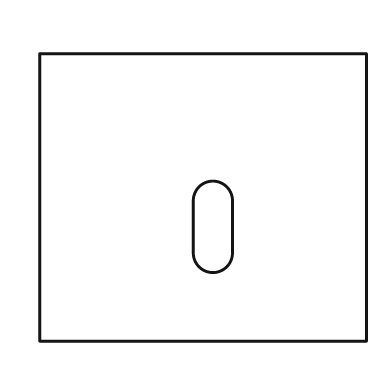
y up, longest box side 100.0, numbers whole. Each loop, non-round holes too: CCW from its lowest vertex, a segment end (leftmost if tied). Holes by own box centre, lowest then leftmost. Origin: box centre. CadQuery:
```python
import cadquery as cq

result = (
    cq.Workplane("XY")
    .moveTo(-50.0, -44.0)
    .lineTo(50.0, -44.0)
    .lineTo(50.0, 44.0)
    .lineTo(-50.0, 44.0)
    .close()
    .moveTo(-3.0, -17.0)
    .threePointArc((3.0, -23.0), (9.0, -17.0))
    .lineTo(9.0, -1.0)
    .threePointArc((3.0, 5.0), (-3.0, -1.0))
    .close()
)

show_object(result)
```